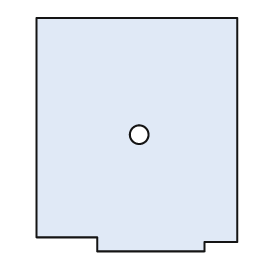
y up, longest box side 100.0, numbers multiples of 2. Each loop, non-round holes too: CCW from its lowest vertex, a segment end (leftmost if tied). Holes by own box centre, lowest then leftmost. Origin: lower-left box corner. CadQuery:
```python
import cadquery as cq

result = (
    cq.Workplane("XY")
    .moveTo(26.0, 0.0)
    .lineTo(72.0, 0.0)
    .lineTo(72.0, 4.0)
    .lineTo(86.0, 4.0)
    .lineTo(86.0, 100.0)
    .lineTo(0.0, 100.0)
    .lineTo(0.0, 6.0)
    .lineTo(26.0, 6.0)
    .close()
    .moveTo(44.0, 50.0)
    .circle(4.0)
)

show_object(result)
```